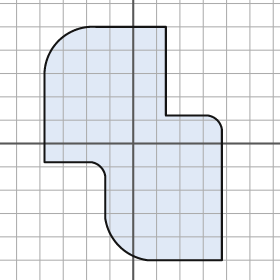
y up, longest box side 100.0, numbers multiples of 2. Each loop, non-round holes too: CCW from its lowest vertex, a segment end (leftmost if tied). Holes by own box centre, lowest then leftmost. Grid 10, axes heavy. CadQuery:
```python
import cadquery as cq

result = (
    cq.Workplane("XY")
    .moveTo(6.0, -50.0)
    .lineTo(38.0, -50.0)
    .lineTo(38.0, 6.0)
    .threePointArc((36.0, 10.0), (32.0, 12.0))
    .lineTo(14.0, 12.0)
    .lineTo(14.0, 50.0)
    .lineTo(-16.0, 50.0)
    .threePointArc((-32.0, 44.0), (-38.0, 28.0))
    .lineTo(-38.0, -8.0)
    .lineTo(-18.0, -8.0)
    .threePointArc((-14.0, -10.0), (-12.0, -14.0))
    .lineTo(-12.0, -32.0)
    .threePointArc((-6.0, -44.0), (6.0, -50.0))
    .close()
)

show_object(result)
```